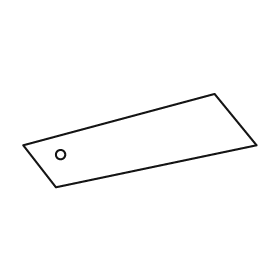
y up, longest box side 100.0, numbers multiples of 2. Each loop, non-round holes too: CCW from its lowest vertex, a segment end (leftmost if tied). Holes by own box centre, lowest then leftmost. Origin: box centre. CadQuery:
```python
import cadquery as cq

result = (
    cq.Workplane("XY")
    .moveTo(-36.0, -20.0)
    .lineTo(50.0, -2.0)
    .lineTo(32.0, 20.0)
    .lineTo(-50.0, -2.0)
    .close()
    .moveTo(-34.0, -6.0)
    .circle(2.0)
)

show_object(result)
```